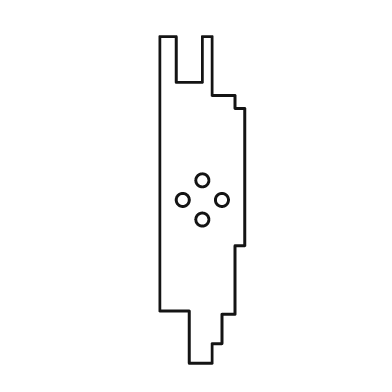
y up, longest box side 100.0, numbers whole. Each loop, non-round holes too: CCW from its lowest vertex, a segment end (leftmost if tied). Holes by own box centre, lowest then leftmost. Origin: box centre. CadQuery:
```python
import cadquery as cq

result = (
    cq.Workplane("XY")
    .moveTo(-4.0, -50.0)
    .lineTo(3.0, -50.0)
    .lineTo(3.0, -44.0)
    .lineTo(6.0, -44.0)
    .lineTo(6.0, -35.0)
    .lineTo(10.0, -35.0)
    .lineTo(10.0, -14.0)
    .lineTo(13.0, -14.0)
    .lineTo(13.0, 28.0)
    .lineTo(10.0, 28.0)
    .lineTo(10.0, 32.0)
    .lineTo(3.0, 32.0)
    .lineTo(3.0, 50.0)
    .lineTo(0.0, 50.0)
    .lineTo(0.0, 36.0)
    .lineTo(-8.0, 36.0)
    .lineTo(-8.0, 50.0)
    .lineTo(-13.0, 50.0)
    .lineTo(-13.0, -34.0)
    .lineTo(-4.0, -34.0)
    .close()
    .moveTo(0.0, -6.0)
    .circle(2.0)
    .moveTo(-6.0, 0.0)
    .circle(2.0)
    .moveTo(6.0, 0.0)
    .circle(2.0)
    .moveTo(0.0, 6.0)
    .circle(2.0)
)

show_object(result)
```